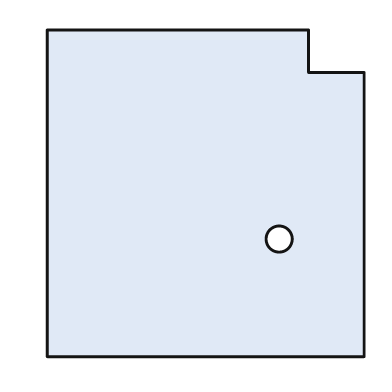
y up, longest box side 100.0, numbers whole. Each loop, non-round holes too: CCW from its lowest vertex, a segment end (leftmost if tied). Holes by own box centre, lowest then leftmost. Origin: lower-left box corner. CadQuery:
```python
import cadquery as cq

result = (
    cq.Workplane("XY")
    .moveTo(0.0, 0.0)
    .lineTo(97.0, 0.0)
    .lineTo(97.0, 87.0)
    .lineTo(80.0, 87.0)
    .lineTo(80.0, 100.0)
    .lineTo(0.0, 100.0)
    .close()
    .moveTo(71.0, 36.0)
    .circle(4.0)
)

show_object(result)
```